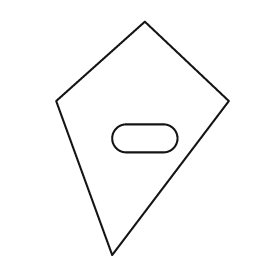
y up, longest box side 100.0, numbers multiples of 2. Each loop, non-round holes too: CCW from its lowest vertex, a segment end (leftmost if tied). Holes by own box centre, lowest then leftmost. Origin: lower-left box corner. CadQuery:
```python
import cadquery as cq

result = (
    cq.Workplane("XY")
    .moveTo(24.0, 0.0)
    .lineTo(74.0, 66.0)
    .lineTo(38.0, 100.0)
    .lineTo(0.0, 66.0)
    .close()
    .moveTo(30.0, 44.0)
    .lineTo(46.0, 44.0)
    .threePointArc((52.0, 50.0), (46.0, 56.0))
    .lineTo(30.0, 56.0)
    .threePointArc((24.0, 50.0), (30.0, 44.0))
    .close()
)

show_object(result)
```